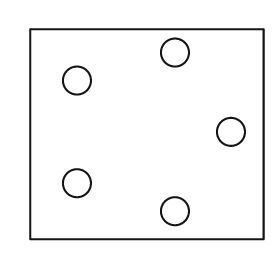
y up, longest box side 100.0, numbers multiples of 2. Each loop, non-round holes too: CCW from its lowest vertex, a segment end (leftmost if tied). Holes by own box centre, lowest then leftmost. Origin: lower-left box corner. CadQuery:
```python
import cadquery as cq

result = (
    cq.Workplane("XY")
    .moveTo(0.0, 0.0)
    .lineTo(100.0, 0.0)
    .lineTo(100.0, 90.0)
    .lineTo(0.0, 90.0)
    .close()
    .moveTo(62.0, 12.0)
    .circle(6.0)
    .moveTo(20.0, 24.0)
    .circle(6.0)
    .moveTo(86.0, 46.0)
    .circle(6.0)
    .moveTo(20.0, 68.0)
    .circle(6.0)
    .moveTo(62.0, 80.0)
    .circle(6.0)
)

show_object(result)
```